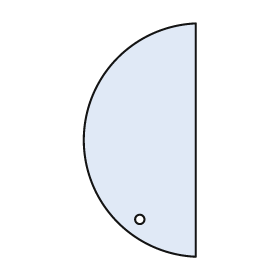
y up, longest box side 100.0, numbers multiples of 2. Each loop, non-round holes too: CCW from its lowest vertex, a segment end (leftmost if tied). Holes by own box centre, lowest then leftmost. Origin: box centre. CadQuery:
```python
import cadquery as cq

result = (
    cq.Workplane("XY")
    .moveTo(24.0, -50.0)
    .lineTo(24.0, 50.0)
    .threePointArc((-24.0, 0.0), (24.0, -50.0))
    .close()
    .moveTo(0.0, -34.0)
    .circle(2.0)
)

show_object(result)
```